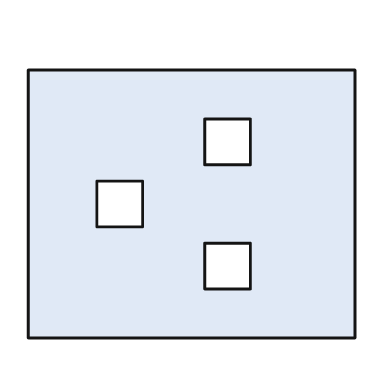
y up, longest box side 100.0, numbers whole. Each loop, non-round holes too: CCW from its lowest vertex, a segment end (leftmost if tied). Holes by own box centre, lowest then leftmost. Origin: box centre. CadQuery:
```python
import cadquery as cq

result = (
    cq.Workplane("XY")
    .moveTo(-50.0, -41.0)
    .lineTo(50.0, -41.0)
    .lineTo(50.0, 41.0)
    .lineTo(-50.0, 41.0)
    .close()
    .moveTo(4.0, -26.0)
    .lineTo(18.0, -26.0)
    .lineTo(18.0, -12.0)
    .lineTo(4.0, -12.0)
    .close()
    .moveTo(-29.0, -7.0)
    .lineTo(-15.0, -7.0)
    .lineTo(-15.0, 7.0)
    .lineTo(-29.0, 7.0)
    .close()
    .moveTo(4.0, 12.0)
    .lineTo(18.0, 12.0)
    .lineTo(18.0, 26.0)
    .lineTo(4.0, 26.0)
    .close()
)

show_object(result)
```